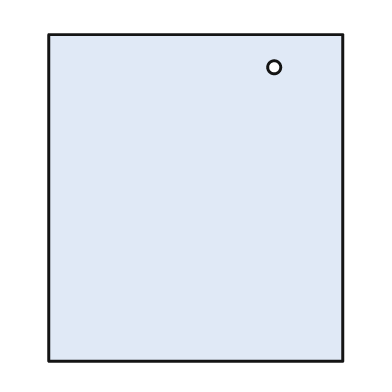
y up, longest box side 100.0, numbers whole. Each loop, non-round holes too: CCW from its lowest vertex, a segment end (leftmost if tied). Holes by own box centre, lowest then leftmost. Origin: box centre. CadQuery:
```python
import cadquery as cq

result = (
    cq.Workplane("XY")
    .moveTo(-45.0, -50.0)
    .lineTo(45.0, -50.0)
    .lineTo(45.0, 50.0)
    .lineTo(-45.0, 50.0)
    .close()
    .moveTo(24.0, 40.0)
    .circle(2.0)
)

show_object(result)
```